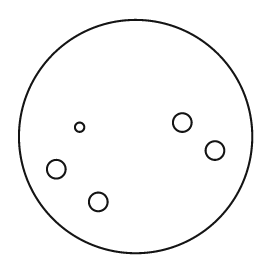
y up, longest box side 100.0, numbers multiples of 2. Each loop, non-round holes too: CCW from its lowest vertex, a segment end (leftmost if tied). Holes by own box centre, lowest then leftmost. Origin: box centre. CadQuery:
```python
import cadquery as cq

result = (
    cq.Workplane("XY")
    .moveTo(0.0, 0.0)
    .circle(50.0)
    .moveTo(-16.0, -28.0)
    .circle(4.0)
    .moveTo(-34.0, -14.0)
    .circle(4.0)
    .moveTo(34.0, -6.0)
    .circle(4.0)
    .moveTo(-24.0, 4.0)
    .circle(2.0)
    .moveTo(20.0, 6.0)
    .circle(4.0)
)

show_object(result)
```